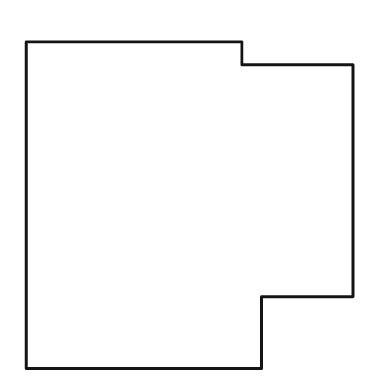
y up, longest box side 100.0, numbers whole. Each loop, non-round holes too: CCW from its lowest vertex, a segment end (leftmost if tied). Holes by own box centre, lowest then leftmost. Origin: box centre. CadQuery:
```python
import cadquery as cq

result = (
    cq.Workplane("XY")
    .moveTo(-50.0, -50.0)
    .lineTo(22.0, -50.0)
    .lineTo(22.0, -28.0)
    .lineTo(50.0, -28.0)
    .lineTo(50.0, 43.0)
    .lineTo(16.0, 43.0)
    .lineTo(16.0, 50.0)
    .lineTo(-50.0, 50.0)
    .close()
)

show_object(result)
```